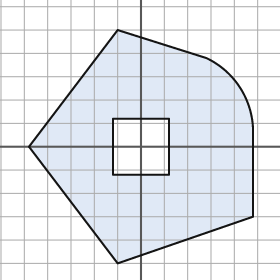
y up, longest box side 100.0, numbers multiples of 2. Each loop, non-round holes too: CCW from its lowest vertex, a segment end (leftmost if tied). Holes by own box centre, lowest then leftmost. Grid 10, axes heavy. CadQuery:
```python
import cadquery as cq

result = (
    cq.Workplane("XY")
    .moveTo(-10.0, -50.0)
    .lineTo(48.0, -30.0)
    .lineTo(48.0, 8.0)
    .threePointArc((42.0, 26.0), (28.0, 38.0))
    .lineTo(-10.0, 50.0)
    .lineTo(-48.0, 0.0)
    .close()
    .moveTo(-12.0, -12.0)
    .lineTo(12.0, -12.0)
    .lineTo(12.0, 12.0)
    .lineTo(-12.0, 12.0)
    .close()
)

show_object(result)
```